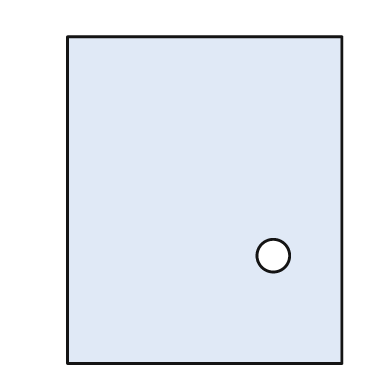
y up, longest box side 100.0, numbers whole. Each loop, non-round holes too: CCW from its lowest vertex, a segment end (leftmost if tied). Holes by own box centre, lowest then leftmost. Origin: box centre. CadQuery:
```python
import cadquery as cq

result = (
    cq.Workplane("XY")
    .moveTo(-42.0, -50.0)
    .lineTo(42.0, -50.0)
    .lineTo(42.0, 50.0)
    .lineTo(-42.0, 50.0)
    .close()
    .moveTo(21.0, -17.0)
    .circle(5.0)
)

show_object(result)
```